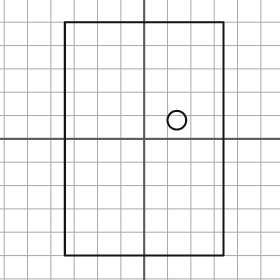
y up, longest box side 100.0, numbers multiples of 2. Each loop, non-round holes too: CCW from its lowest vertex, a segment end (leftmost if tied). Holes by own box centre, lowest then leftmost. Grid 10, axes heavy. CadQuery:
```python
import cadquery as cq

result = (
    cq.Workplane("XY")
    .moveTo(-34.0, -50.0)
    .lineTo(34.0, -50.0)
    .lineTo(34.0, 50.0)
    .lineTo(-34.0, 50.0)
    .close()
    .moveTo(14.0, 8.0)
    .circle(4.0)
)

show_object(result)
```